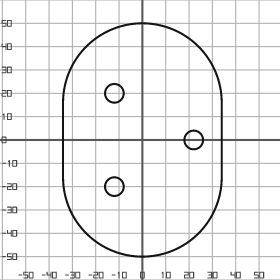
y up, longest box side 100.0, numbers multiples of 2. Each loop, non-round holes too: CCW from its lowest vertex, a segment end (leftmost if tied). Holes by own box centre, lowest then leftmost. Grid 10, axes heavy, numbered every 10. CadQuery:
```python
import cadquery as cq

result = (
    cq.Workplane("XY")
    .moveTo(-34.0, -16.0)
    .threePointArc((0.0, -50.0), (34.0, -16.0))
    .lineTo(34.0, 16.0)
    .threePointArc((0.0, 50.0), (-34.0, 16.0))
    .close()
    .moveTo(-12.0, -20.0)
    .circle(4.0)
    .moveTo(22.0, 0.0)
    .circle(4.0)
    .moveTo(-12.0, 20.0)
    .circle(4.0)
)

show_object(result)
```